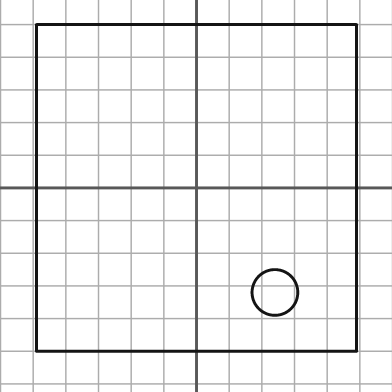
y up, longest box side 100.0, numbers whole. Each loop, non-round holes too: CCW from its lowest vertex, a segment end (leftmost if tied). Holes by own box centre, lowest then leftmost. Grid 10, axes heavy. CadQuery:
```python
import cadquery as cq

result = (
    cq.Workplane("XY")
    .moveTo(-49.0, -50.0)
    .lineTo(49.0, -50.0)
    .lineTo(49.0, 50.0)
    .lineTo(-49.0, 50.0)
    .close()
    .moveTo(24.0, -32.0)
    .circle(7.0)
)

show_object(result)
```